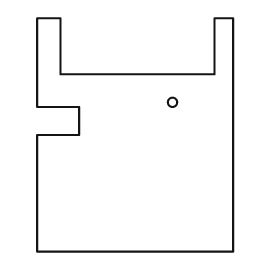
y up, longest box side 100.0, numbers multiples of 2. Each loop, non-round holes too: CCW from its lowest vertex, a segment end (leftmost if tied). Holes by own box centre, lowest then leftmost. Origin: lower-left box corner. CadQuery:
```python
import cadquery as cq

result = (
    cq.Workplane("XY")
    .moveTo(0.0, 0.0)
    .lineTo(84.0, 0.0)
    .lineTo(84.0, 100.0)
    .lineTo(76.0, 100.0)
    .lineTo(76.0, 76.0)
    .lineTo(10.0, 76.0)
    .lineTo(10.0, 100.0)
    .lineTo(0.0, 100.0)
    .lineTo(0.0, 62.0)
    .lineTo(18.0, 62.0)
    .lineTo(18.0, 50.0)
    .lineTo(0.0, 50.0)
    .close()
    .moveTo(58.0, 64.0)
    .circle(2.0)
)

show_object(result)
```